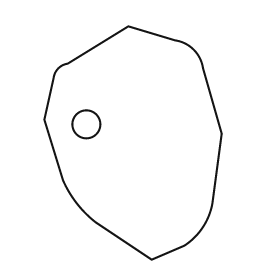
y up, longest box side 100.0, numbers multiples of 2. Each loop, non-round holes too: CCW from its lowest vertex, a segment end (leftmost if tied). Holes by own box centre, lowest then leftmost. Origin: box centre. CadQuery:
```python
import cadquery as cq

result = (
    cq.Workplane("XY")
    .moveTo(8.0, -50.0)
    .lineTo(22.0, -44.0)
    .threePointArc((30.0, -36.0), (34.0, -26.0))
    .lineTo(38.0, 4.0)
    .lineTo(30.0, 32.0)
    .threePointArc((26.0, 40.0), (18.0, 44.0))
    .lineTo(-2.0, 50.0)
    .lineTo(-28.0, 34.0)
    .threePointArc((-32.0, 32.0), (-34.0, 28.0))
    .lineTo(-38.0, 10.0)
    .lineTo(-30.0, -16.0)
    .threePointArc((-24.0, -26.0), (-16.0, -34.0))
    .close()
    .moveTo(-20.0, 8.0)
    .circle(6.0)
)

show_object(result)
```